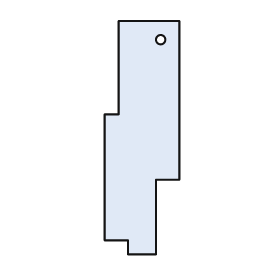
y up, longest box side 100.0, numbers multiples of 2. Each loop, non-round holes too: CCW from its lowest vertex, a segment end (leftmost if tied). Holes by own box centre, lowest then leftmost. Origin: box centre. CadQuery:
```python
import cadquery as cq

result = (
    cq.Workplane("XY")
    .moveTo(-6.0, -50.0)
    .lineTo(6.0, -50.0)
    .lineTo(6.0, -18.0)
    .lineTo(16.0, -18.0)
    .lineTo(16.0, 50.0)
    .lineTo(-10.0, 50.0)
    .lineTo(-10.0, 10.0)
    .lineTo(-16.0, 10.0)
    .lineTo(-16.0, -44.0)
    .lineTo(-6.0, -44.0)
    .close()
    .moveTo(8.0, 42.0)
    .circle(2.0)
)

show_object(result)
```